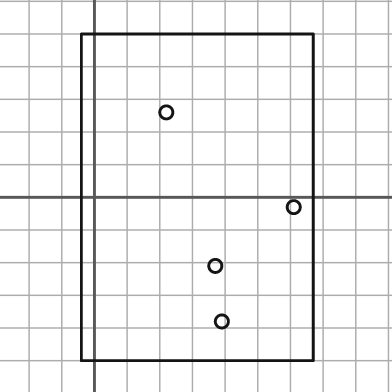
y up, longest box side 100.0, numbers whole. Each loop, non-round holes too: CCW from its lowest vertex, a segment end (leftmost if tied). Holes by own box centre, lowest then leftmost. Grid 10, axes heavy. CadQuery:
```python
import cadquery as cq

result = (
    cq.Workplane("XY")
    .moveTo(-4.0, -50.0)
    .lineTo(67.0, -50.0)
    .lineTo(67.0, 50.0)
    .lineTo(-4.0, 50.0)
    .close()
    .moveTo(39.0, -38.0)
    .circle(2.0)
    .moveTo(37.0, -21.0)
    .circle(2.0)
    .moveTo(61.0, -3.0)
    .circle(2.0)
    .moveTo(22.0, 26.0)
    .circle(2.0)
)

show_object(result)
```